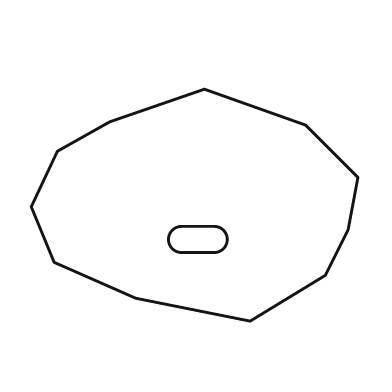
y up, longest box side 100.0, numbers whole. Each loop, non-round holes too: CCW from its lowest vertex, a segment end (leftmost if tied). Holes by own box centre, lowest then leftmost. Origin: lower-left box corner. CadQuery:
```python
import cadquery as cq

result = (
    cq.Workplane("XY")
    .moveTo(67.0, 0.0)
    .lineTo(90.0, 14.0)
    .lineTo(97.0, 28.0)
    .lineTo(100.0, 44.0)
    .lineTo(84.0, 60.0)
    .lineTo(53.0, 71.0)
    .lineTo(24.0, 61.0)
    .lineTo(8.0, 52.0)
    .lineTo(0.0, 35.0)
    .lineTo(7.0, 18.0)
    .lineTo(32.0, 7.0)
    .close()
    .moveTo(46.0, 21.0)
    .lineTo(56.0, 21.0)
    .threePointArc((60.0, 25.0), (56.0, 29.0))
    .lineTo(46.0, 29.0)
    .threePointArc((42.0, 25.0), (46.0, 21.0))
    .close()
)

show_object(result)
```